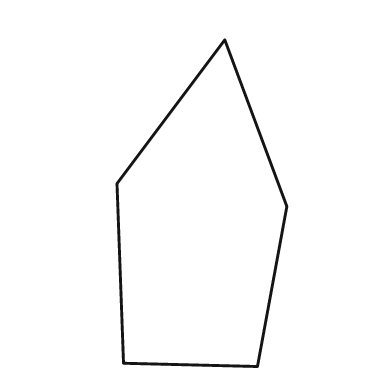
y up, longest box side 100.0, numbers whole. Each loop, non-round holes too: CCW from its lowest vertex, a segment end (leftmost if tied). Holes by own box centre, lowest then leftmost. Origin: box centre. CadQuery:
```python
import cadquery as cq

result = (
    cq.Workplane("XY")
    .moveTo(17.0, -50.0)
    .lineTo(26.0, -1.0)
    .lineTo(7.0, 50.0)
    .lineTo(-26.0, 6.0)
    .lineTo(-24.0, -49.0)
    .close()
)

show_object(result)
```